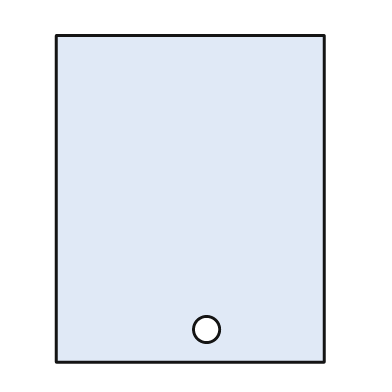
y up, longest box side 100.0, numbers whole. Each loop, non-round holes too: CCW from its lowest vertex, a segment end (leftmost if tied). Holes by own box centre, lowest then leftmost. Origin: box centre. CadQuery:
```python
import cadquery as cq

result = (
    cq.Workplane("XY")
    .moveTo(-41.0, -50.0)
    .lineTo(41.0, -50.0)
    .lineTo(41.0, 50.0)
    .lineTo(-41.0, 50.0)
    .close()
    .moveTo(5.0, -40.0)
    .circle(4.0)
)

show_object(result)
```